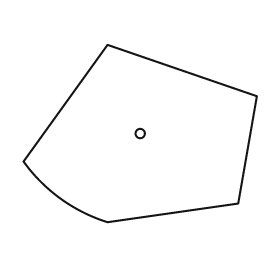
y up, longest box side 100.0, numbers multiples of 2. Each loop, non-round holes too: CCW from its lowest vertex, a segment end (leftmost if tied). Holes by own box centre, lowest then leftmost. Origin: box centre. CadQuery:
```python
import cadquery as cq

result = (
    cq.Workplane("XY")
    .moveTo(-14.0, -38.0)
    .lineTo(42.0, -30.0)
    .lineTo(50.0, 16.0)
    .lineTo(-14.0, 38.0)
    .lineTo(-50.0, -12.0)
    .threePointArc((-34.0, -28.0), (-14.0, -38.0))
    .close()
    .moveTo(0.0, 0.0)
    .circle(2.0)
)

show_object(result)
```